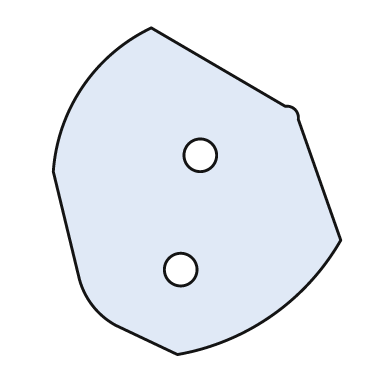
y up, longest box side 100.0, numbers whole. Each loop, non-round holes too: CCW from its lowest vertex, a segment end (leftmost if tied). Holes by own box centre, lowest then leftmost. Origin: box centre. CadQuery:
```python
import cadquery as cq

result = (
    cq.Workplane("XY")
    .moveTo(-6.0, -50.0)
    .threePointArc((23.0, -38.0), (44.0, -15.0))
    .lineTo(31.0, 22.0)
    .threePointArc((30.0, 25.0), (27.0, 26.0))
    .lineTo(-14.0, 50.0)
    .threePointArc((-35.0, 32.0), (-44.0, 6.0))
    .lineTo(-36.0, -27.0)
    .threePointArc((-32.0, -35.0), (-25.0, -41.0))
    .close()
    .moveTo(-5.0, -24.0)
    .circle(5.0)
    .moveTo(1.0, 11.0)
    .circle(5.0)
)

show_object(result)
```